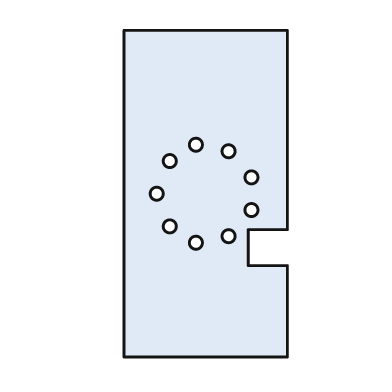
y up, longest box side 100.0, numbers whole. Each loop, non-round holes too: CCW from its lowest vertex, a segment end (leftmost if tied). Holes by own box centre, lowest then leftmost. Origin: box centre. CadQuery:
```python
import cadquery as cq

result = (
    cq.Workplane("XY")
    .moveTo(-25.0, -50.0)
    .lineTo(25.0, -50.0)
    .lineTo(25.0, -22.0)
    .lineTo(13.0, -22.0)
    .lineTo(13.0, -11.0)
    .lineTo(25.0, -11.0)
    .lineTo(25.0, 50.0)
    .lineTo(-25.0, 50.0)
    .close()
    .moveTo(-3.0, -15.0)
    .circle(2.0)
    .moveTo(7.0, -13.0)
    .circle(2.0)
    .moveTo(-11.0, -10.0)
    .circle(2.0)
    .moveTo(14.0, -5.0)
    .circle(2.0)
    .moveTo(-15.0, 0.0)
    .circle(2.0)
    .moveTo(14.0, 5.0)
    .circle(2.0)
    .moveTo(-11.0, 10.0)
    .circle(2.0)
    .moveTo(7.0, 13.0)
    .circle(2.0)
    .moveTo(-3.0, 15.0)
    .circle(2.0)
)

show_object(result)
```